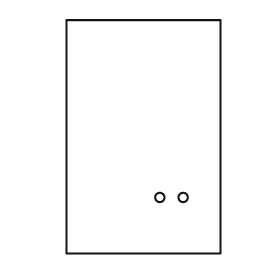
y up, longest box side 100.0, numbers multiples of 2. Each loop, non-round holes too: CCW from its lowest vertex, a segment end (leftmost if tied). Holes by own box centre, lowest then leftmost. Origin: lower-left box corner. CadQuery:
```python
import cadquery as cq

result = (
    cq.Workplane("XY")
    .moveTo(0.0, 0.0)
    .lineTo(66.0, 0.0)
    .lineTo(66.0, 100.0)
    .lineTo(0.0, 100.0)
    .close()
    .moveTo(40.0, 24.0)
    .circle(2.0)
    .moveTo(50.0, 24.0)
    .circle(2.0)
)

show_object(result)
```